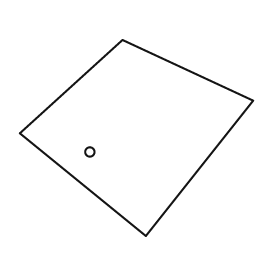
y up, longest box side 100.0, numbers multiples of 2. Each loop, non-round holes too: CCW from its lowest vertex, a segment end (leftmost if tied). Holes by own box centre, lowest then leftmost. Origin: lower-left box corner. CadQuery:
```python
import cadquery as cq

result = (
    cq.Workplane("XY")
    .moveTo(54.0, 0.0)
    .lineTo(100.0, 58.0)
    .lineTo(44.0, 84.0)
    .lineTo(0.0, 44.0)
    .close()
    .moveTo(30.0, 36.0)
    .circle(2.0)
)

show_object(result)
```